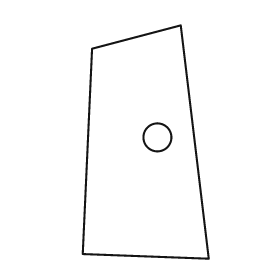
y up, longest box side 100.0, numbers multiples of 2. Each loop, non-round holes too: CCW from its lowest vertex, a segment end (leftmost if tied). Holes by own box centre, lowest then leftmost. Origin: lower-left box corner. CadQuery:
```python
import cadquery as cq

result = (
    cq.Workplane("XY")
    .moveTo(54.0, 0.0)
    .lineTo(42.0, 100.0)
    .lineTo(4.0, 90.0)
    .lineTo(0.0, 2.0)
    .close()
    .moveTo(32.0, 52.0)
    .circle(6.0)
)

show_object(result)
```